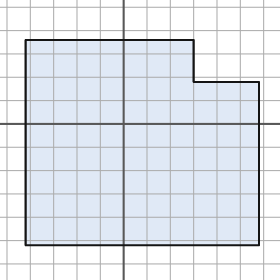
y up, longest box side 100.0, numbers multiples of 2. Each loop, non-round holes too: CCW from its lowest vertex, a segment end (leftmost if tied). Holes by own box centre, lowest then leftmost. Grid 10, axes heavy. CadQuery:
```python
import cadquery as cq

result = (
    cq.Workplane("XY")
    .moveTo(-42.0, -52.0)
    .lineTo(58.0, -52.0)
    .lineTo(58.0, 18.0)
    .lineTo(30.0, 18.0)
    .lineTo(30.0, 36.0)
    .lineTo(-42.0, 36.0)
    .close()
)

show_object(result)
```